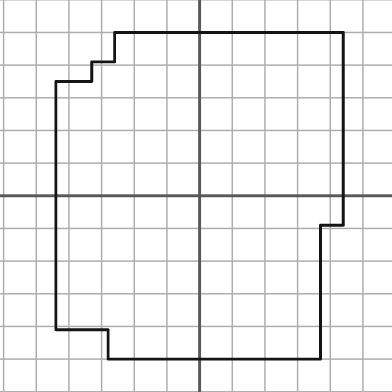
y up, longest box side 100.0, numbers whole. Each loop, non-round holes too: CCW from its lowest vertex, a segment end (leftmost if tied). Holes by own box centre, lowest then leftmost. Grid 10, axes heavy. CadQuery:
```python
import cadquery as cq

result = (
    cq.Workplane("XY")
    .moveTo(-28.0, -50.0)
    .lineTo(37.0, -50.0)
    .lineTo(37.0, -9.0)
    .lineTo(44.0, -9.0)
    .lineTo(44.0, 50.0)
    .lineTo(-26.0, 50.0)
    .lineTo(-26.0, 41.0)
    .lineTo(-33.0, 41.0)
    .lineTo(-33.0, 35.0)
    .lineTo(-44.0, 35.0)
    .lineTo(-44.0, -41.0)
    .lineTo(-28.0, -41.0)
    .close()
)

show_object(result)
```